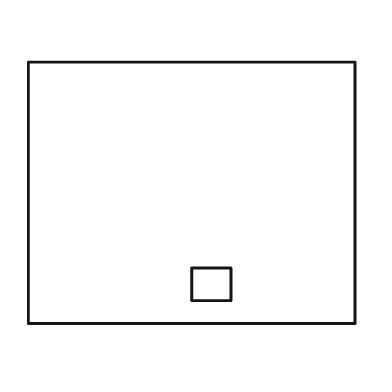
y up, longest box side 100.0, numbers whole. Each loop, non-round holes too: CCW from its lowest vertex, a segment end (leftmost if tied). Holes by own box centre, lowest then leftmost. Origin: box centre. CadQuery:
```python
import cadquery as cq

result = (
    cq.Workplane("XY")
    .moveTo(-50.0, -40.0)
    .lineTo(50.0, -40.0)
    .lineTo(50.0, 40.0)
    .lineTo(-50.0, 40.0)
    .close()
    .moveTo(0.0, -33.0)
    .lineTo(12.0, -33.0)
    .lineTo(12.0, -23.0)
    .lineTo(0.0, -23.0)
    .close()
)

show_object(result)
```